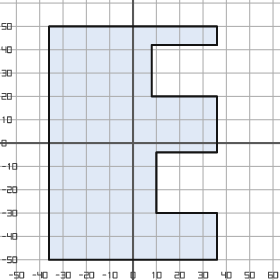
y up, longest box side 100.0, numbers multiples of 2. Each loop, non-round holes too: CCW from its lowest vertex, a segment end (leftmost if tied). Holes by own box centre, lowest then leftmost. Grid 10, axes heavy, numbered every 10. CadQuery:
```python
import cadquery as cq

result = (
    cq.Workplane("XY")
    .moveTo(-36.0, -50.0)
    .lineTo(36.0, -50.0)
    .lineTo(36.0, -30.0)
    .lineTo(10.0, -30.0)
    .lineTo(10.0, -4.0)
    .lineTo(36.0, -4.0)
    .lineTo(36.0, 20.0)
    .lineTo(8.0, 20.0)
    .lineTo(8.0, 42.0)
    .lineTo(36.0, 42.0)
    .lineTo(36.0, 50.0)
    .lineTo(-36.0, 50.0)
    .close()
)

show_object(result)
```